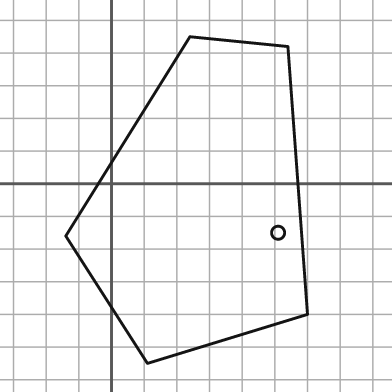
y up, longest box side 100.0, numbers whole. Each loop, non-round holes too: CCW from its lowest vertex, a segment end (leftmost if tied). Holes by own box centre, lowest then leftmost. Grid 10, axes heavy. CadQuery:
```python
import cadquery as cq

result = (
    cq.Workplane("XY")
    .moveTo(11.0, -55.0)
    .lineTo(60.0, -40.0)
    .lineTo(54.0, 42.0)
    .lineTo(24.0, 45.0)
    .lineTo(-14.0, -16.0)
    .close()
    .moveTo(51.0, -15.0)
    .circle(2.0)
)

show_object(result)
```